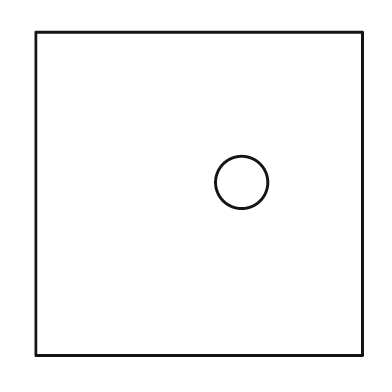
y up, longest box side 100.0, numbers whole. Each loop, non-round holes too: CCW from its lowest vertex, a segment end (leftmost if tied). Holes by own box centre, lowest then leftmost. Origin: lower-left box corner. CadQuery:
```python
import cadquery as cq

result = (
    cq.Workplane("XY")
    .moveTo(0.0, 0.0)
    .lineTo(100.0, 0.0)
    .lineTo(100.0, 99.0)
    .lineTo(0.0, 99.0)
    .close()
    .moveTo(63.0, 53.0)
    .circle(8.0)
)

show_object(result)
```